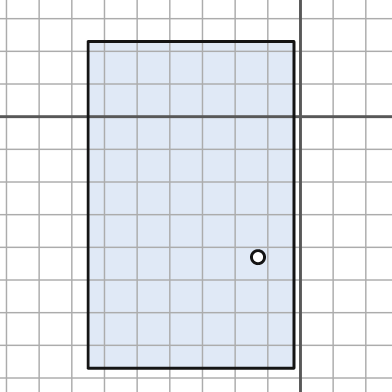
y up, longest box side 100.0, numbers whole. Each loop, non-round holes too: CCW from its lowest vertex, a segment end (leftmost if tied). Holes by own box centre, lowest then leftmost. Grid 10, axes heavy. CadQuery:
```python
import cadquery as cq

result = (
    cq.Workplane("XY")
    .moveTo(-65.0, -77.0)
    .lineTo(-2.0, -77.0)
    .lineTo(-2.0, 23.0)
    .lineTo(-65.0, 23.0)
    .close()
    .moveTo(-13.0, -43.0)
    .circle(2.0)
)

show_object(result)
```